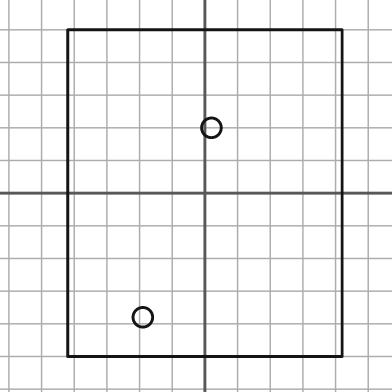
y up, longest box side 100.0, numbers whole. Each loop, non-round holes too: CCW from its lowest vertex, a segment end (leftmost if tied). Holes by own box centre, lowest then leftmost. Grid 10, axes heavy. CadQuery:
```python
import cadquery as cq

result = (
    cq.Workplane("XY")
    .moveTo(-42.0, -50.0)
    .lineTo(42.0, -50.0)
    .lineTo(42.0, 50.0)
    .lineTo(-42.0, 50.0)
    .close()
    .moveTo(-19.0, -38.0)
    .circle(3.0)
    .moveTo(2.0, 20.0)
    .circle(3.0)
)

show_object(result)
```